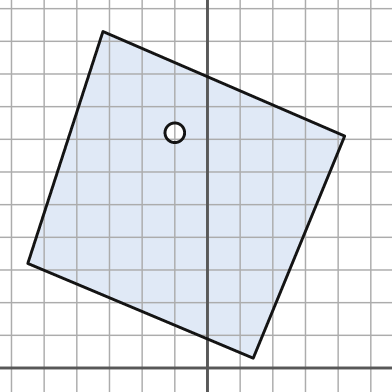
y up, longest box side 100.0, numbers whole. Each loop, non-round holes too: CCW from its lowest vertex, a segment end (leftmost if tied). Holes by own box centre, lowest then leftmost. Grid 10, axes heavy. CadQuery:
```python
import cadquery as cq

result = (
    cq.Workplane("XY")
    .moveTo(14.0, 3.0)
    .lineTo(42.0, 71.0)
    .lineTo(-32.0, 103.0)
    .lineTo(-55.0, 32.0)
    .close()
    .moveTo(-10.0, 72.0)
    .circle(3.0)
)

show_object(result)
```